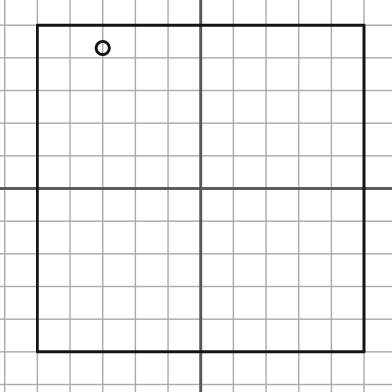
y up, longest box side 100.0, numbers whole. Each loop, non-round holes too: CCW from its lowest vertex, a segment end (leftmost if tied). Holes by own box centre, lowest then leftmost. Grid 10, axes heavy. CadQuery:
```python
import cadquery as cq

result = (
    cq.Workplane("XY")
    .moveTo(-50.0, -50.0)
    .lineTo(50.0, -50.0)
    .lineTo(50.0, 50.0)
    .lineTo(-50.0, 50.0)
    .close()
    .moveTo(-30.0, 43.0)
    .circle(2.0)
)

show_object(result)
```